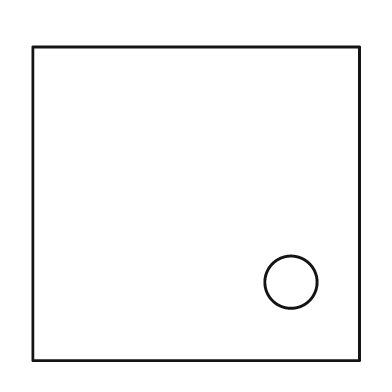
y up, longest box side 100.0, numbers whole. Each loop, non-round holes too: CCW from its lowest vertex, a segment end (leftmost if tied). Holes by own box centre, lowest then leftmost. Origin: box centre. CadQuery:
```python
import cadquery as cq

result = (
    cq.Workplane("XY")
    .moveTo(-50.0, -48.0)
    .lineTo(50.0, -48.0)
    .lineTo(50.0, 48.0)
    .lineTo(-50.0, 48.0)
    .close()
    .moveTo(29.0, -24.0)
    .circle(8.0)
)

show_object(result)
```